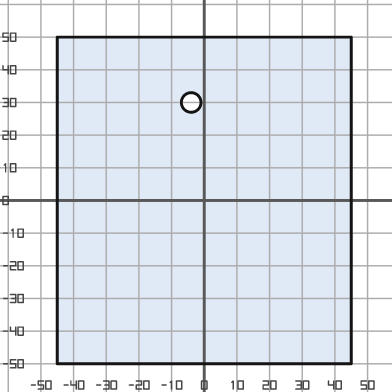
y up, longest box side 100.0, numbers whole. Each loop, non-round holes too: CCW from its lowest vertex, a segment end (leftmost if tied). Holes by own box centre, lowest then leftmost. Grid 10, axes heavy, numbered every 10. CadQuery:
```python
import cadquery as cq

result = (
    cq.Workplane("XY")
    .moveTo(-45.0, -50.0)
    .lineTo(45.0, -50.0)
    .lineTo(45.0, 50.0)
    .lineTo(-45.0, 50.0)
    .close()
    .moveTo(-4.0, 30.0)
    .circle(3.0)
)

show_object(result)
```